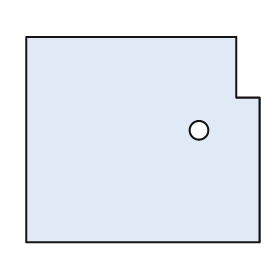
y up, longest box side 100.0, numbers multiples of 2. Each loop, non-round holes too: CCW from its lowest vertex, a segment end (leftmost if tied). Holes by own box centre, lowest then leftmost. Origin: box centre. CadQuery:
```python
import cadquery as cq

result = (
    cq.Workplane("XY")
    .moveTo(-50.0, -44.0)
    .lineTo(50.0, -44.0)
    .lineTo(50.0, 18.0)
    .lineTo(40.0, 18.0)
    .lineTo(40.0, 44.0)
    .lineTo(-50.0, 44.0)
    .close()
    .moveTo(24.0, 4.0)
    .circle(4.0)
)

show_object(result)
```